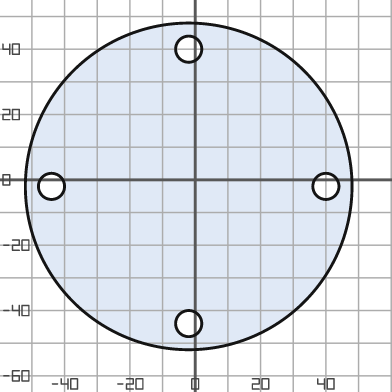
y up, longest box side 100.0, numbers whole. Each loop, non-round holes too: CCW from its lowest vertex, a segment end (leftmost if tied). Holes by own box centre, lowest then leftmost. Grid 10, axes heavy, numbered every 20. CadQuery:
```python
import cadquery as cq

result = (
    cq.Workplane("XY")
    .moveTo(-2.0, -2.0)
    .circle(50.0)
    .moveTo(-2.0, -44.0)
    .circle(4.0)
    .moveTo(-44.0, -2.0)
    .circle(4.0)
    .moveTo(40.0, -2.0)
    .circle(4.0)
    .moveTo(-2.0, 40.0)
    .circle(4.0)
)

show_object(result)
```